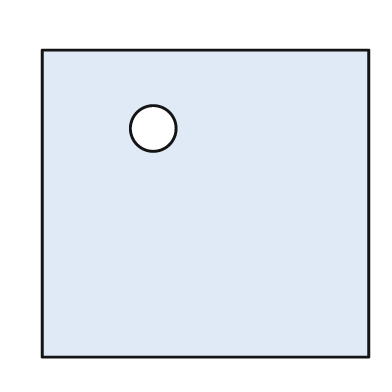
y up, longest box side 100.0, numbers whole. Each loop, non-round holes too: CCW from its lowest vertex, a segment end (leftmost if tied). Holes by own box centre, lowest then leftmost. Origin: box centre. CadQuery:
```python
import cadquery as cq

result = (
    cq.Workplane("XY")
    .moveTo(-50.0, -47.0)
    .lineTo(50.0, -47.0)
    .lineTo(50.0, 47.0)
    .lineTo(-50.0, 47.0)
    .close()
    .moveTo(-16.0, 23.0)
    .circle(7.0)
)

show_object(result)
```